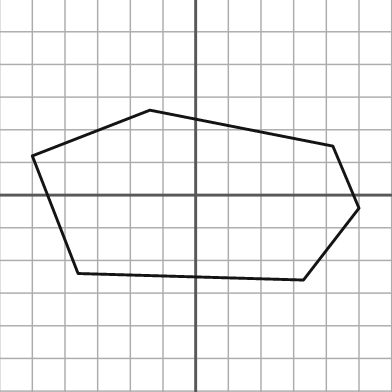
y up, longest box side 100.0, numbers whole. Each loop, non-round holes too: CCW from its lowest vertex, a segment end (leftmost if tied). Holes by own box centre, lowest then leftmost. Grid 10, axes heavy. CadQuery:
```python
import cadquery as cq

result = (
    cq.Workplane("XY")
    .moveTo(33.0, -26.0)
    .lineTo(50.0, -4.0)
    .lineTo(42.0, 15.0)
    .lineTo(-14.0, 26.0)
    .lineTo(-50.0, 12.0)
    .lineTo(-36.0, -24.0)
    .close()
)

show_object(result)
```